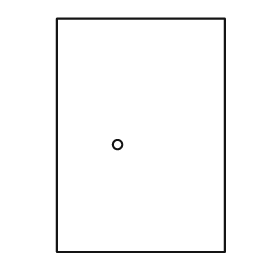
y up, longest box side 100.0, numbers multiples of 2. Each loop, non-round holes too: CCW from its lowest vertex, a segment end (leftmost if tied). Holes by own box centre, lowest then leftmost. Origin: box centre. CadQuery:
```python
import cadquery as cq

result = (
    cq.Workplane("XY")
    .moveTo(-36.0, -50.0)
    .lineTo(36.0, -50.0)
    .lineTo(36.0, 50.0)
    .lineTo(-36.0, 50.0)
    .close()
    .moveTo(-10.0, -4.0)
    .circle(2.0)
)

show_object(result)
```